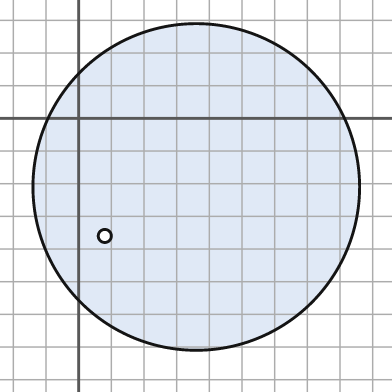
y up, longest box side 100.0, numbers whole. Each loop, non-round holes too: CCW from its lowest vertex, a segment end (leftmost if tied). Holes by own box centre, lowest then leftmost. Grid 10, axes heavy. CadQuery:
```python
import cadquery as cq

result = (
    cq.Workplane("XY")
    .moveTo(36.0, -21.0)
    .circle(50.0)
    .moveTo(8.0, -36.0)
    .circle(2.0)
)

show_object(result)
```